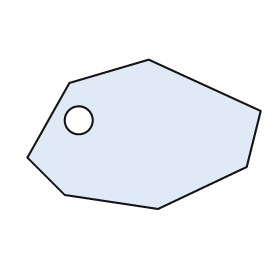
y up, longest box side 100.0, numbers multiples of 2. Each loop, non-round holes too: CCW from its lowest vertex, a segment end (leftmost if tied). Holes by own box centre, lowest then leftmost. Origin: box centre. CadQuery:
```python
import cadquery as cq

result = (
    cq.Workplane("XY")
    .moveTo(6.0, -32.0)
    .lineTo(44.0, -14.0)
    .lineTo(50.0, 10.0)
    .lineTo(2.0, 32.0)
    .lineTo(-32.0, 22.0)
    .lineTo(-50.0, -10.0)
    .lineTo(-34.0, -26.0)
    .close()
    .moveTo(-28.0, 6.0)
    .circle(6.0)
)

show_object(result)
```